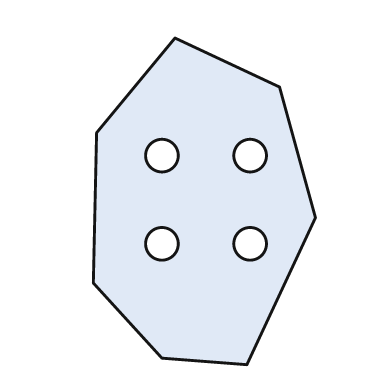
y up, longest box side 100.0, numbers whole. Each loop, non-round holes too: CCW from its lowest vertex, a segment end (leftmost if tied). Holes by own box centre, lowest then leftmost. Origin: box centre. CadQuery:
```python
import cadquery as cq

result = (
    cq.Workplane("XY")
    .moveTo(13.0, -50.0)
    .lineTo(34.0, -5.0)
    .lineTo(23.0, 35.0)
    .lineTo(-9.0, 50.0)
    .lineTo(-33.0, 21.0)
    .lineTo(-34.0, -25.0)
    .lineTo(-13.0, -48.0)
    .close()
    .moveTo(-13.0, -13.0)
    .circle(5.0)
    .moveTo(14.0, -13.0)
    .circle(5.0)
    .moveTo(-13.0, 14.0)
    .circle(5.0)
    .moveTo(14.0, 14.0)
    .circle(5.0)
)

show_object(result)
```